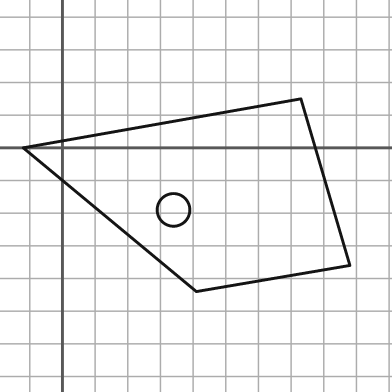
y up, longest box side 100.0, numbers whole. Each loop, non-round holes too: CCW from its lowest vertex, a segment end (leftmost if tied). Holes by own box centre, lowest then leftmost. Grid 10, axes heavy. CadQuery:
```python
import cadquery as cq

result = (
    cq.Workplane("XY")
    .moveTo(41.0, -44.0)
    .lineTo(88.0, -36.0)
    .lineTo(73.0, 15.0)
    .lineTo(-12.0, 0.0)
    .close()
    .moveTo(34.0, -19.0)
    .circle(5.0)
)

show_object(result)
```